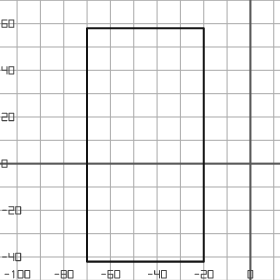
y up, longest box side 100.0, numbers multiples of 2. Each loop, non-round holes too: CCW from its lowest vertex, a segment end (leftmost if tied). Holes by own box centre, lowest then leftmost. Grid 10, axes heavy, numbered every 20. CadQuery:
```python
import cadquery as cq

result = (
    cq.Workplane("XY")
    .moveTo(-70.0, -42.0)
    .lineTo(-20.0, -42.0)
    .lineTo(-20.0, 58.0)
    .lineTo(-70.0, 58.0)
    .close()
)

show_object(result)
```